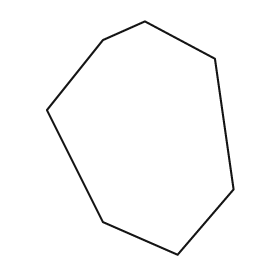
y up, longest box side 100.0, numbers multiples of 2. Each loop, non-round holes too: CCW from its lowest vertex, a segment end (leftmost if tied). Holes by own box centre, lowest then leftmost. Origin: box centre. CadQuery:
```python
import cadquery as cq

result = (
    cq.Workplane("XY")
    .moveTo(16.0, -50.0)
    .lineTo(40.0, -22.0)
    .lineTo(32.0, 34.0)
    .lineTo(2.0, 50.0)
    .lineTo(-16.0, 42.0)
    .lineTo(-40.0, 12.0)
    .lineTo(-16.0, -36.0)
    .close()
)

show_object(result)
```